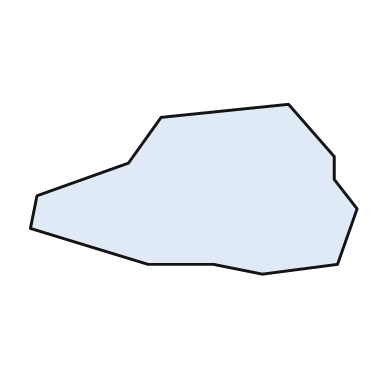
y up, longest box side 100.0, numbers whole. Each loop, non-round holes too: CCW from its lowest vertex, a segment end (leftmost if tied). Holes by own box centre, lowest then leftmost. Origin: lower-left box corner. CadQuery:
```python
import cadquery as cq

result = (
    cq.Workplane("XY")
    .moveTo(71.0, 0.0)
    .lineTo(94.0, 3.0)
    .lineTo(100.0, 20.0)
    .lineTo(93.0, 29.0)
    .lineTo(93.0, 36.0)
    .lineTo(79.0, 52.0)
    .lineTo(40.0, 48.0)
    .lineTo(30.0, 34.0)
    .lineTo(2.0, 24.0)
    .lineTo(0.0, 14.0)
    .lineTo(36.0, 3.0)
    .lineTo(56.0, 3.0)
    .close()
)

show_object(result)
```